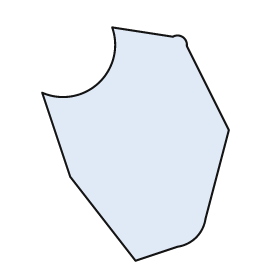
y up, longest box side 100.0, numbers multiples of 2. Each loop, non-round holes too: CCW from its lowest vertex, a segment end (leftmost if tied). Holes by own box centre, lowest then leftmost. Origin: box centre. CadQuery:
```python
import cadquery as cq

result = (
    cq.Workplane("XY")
    .moveTo(0.0, -50.0)
    .lineTo(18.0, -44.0)
    .threePointArc((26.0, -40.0), (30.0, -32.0))
    .lineTo(40.0, 6.0)
    .lineTo(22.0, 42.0)
    .threePointArc((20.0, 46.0), (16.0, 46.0))
    .lineTo(-10.0, 50.0)
    .threePointArc((-16.0, 26.0), (-40.0, 22.0))
    .lineTo(-28.0, -14.0)
    .close()
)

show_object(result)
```